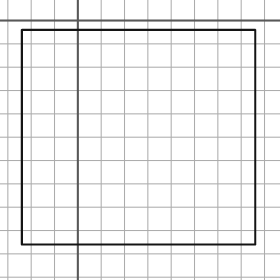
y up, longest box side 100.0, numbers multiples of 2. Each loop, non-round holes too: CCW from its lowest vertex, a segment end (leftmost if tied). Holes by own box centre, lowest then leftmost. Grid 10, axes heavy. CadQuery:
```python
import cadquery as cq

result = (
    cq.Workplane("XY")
    .moveTo(-24.0, -96.0)
    .lineTo(76.0, -96.0)
    .lineTo(76.0, -4.0)
    .lineTo(-24.0, -4.0)
    .close()
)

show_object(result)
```